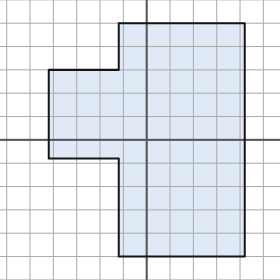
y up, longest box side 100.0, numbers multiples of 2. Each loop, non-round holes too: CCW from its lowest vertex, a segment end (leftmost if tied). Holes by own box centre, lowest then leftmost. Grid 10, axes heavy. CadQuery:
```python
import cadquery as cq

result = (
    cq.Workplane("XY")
    .moveTo(-12.0, -50.0)
    .lineTo(42.0, -50.0)
    .lineTo(42.0, 50.0)
    .lineTo(-12.0, 50.0)
    .lineTo(-12.0, 30.0)
    .lineTo(-42.0, 30.0)
    .lineTo(-42.0, -8.0)
    .lineTo(-12.0, -8.0)
    .close()
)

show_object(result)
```